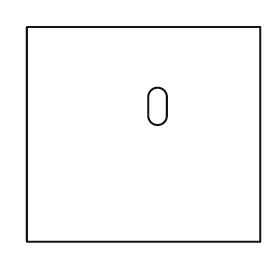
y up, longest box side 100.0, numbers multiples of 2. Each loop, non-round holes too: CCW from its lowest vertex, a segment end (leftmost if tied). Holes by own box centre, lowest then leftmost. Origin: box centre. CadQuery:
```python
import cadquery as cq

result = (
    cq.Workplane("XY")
    .moveTo(-50.0, -46.0)
    .lineTo(50.0, -46.0)
    .lineTo(50.0, 46.0)
    .lineTo(-50.0, 46.0)
    .close()
    .moveTo(2.0, 8.0)
    .threePointArc((6.0, 4.0), (10.0, 8.0))
    .lineTo(10.0, 16.0)
    .threePointArc((6.0, 20.0), (2.0, 16.0))
    .close()
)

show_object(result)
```